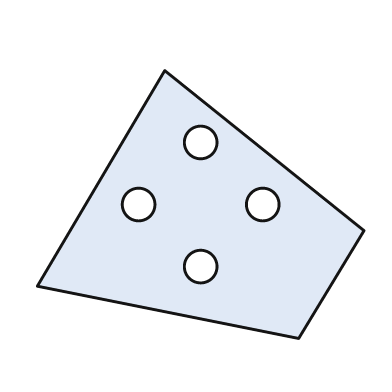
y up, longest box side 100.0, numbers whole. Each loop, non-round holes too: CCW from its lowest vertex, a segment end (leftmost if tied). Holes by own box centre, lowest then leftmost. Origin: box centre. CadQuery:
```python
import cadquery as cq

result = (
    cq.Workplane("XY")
    .moveTo(30.0, -41.0)
    .lineTo(50.0, -8.0)
    .lineTo(-11.0, 41.0)
    .lineTo(-50.0, -25.0)
    .close()
    .moveTo(0.0, -19.0)
    .circle(5.0)
    .moveTo(-19.0, 0.0)
    .circle(5.0)
    .moveTo(19.0, 0.0)
    .circle(5.0)
    .moveTo(0.0, 19.0)
    .circle(5.0)
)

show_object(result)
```